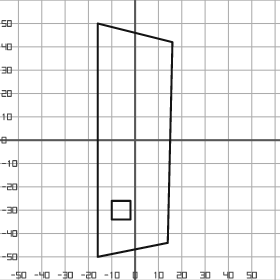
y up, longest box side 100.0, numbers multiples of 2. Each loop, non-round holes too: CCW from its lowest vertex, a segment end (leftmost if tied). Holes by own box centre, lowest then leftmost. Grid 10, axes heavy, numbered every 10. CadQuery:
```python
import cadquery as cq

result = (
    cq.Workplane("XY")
    .moveTo(-16.0, -50.0)
    .lineTo(14.0, -44.0)
    .lineTo(16.0, 42.0)
    .lineTo(-16.0, 50.0)
    .close()
    .moveTo(-10.0, -34.0)
    .lineTo(-2.0, -34.0)
    .lineTo(-2.0, -26.0)
    .lineTo(-10.0, -26.0)
    .close()
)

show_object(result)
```